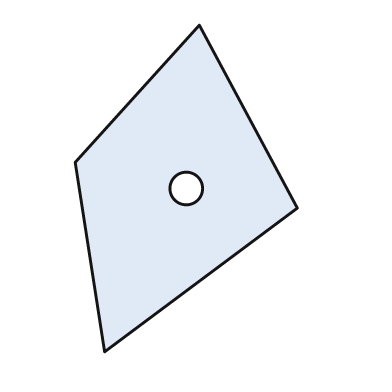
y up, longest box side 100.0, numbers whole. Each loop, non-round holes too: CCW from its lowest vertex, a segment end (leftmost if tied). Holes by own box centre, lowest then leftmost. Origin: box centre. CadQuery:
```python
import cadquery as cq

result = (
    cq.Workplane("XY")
    .moveTo(-25.0, -50.0)
    .lineTo(34.0, -6.0)
    .lineTo(4.0, 50.0)
    .lineTo(-34.0, 8.0)
    .close()
    .moveTo(0.0, 0.0)
    .circle(5.0)
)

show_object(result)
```